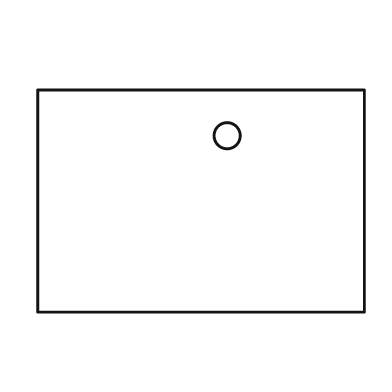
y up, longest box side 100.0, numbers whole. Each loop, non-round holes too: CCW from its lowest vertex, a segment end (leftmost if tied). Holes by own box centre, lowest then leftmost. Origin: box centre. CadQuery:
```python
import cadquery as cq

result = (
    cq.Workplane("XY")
    .moveTo(-50.0, -34.0)
    .lineTo(50.0, -34.0)
    .lineTo(50.0, 34.0)
    .lineTo(-50.0, 34.0)
    .close()
    .moveTo(8.0, 20.0)
    .circle(4.0)
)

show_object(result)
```